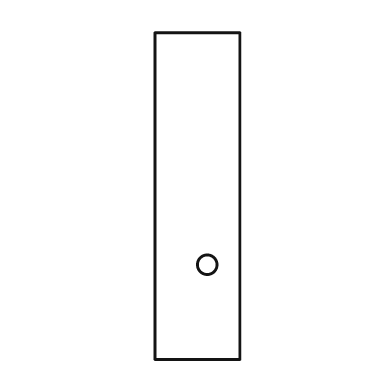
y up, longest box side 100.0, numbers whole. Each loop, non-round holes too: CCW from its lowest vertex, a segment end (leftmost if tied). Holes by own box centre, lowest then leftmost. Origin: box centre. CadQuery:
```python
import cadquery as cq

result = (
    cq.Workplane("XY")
    .moveTo(-13.0, -50.0)
    .lineTo(13.0, -50.0)
    .lineTo(13.0, 50.0)
    .lineTo(-13.0, 50.0)
    .close()
    .moveTo(3.0, -21.0)
    .circle(3.0)
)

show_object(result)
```